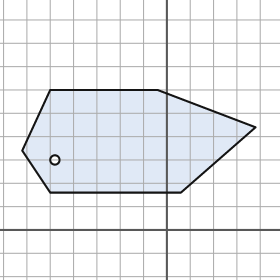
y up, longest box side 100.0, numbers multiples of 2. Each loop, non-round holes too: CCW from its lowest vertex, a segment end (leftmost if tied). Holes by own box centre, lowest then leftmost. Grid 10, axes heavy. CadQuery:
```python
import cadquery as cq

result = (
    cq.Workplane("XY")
    .moveTo(-50.0, 16.0)
    .lineTo(6.0, 16.0)
    .lineTo(38.0, 44.0)
    .lineTo(-4.0, 60.0)
    .lineTo(-50.0, 60.0)
    .lineTo(-62.0, 34.0)
    .close()
    .moveTo(-48.0, 30.0)
    .circle(2.0)
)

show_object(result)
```